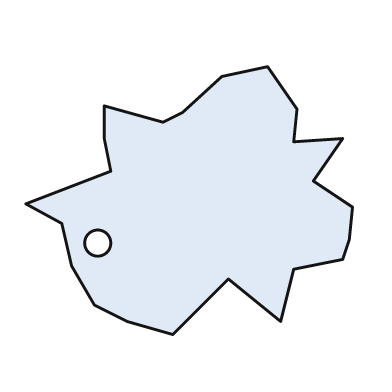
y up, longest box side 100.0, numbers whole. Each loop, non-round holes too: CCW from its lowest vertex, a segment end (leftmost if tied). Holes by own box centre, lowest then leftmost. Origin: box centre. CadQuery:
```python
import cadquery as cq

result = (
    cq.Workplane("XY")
    .moveTo(-5.0, -41.0)
    .lineTo(12.0, -24.0)
    .lineTo(28.0, -37.0)
    .lineTo(32.0, -21.0)
    .lineTo(47.0, -18.0)
    .lineTo(49.0, -12.0)
    .lineTo(50.0, -2.0)
    .lineTo(38.0, 6.0)
    .lineTo(47.0, 19.0)
    .lineTo(32.0, 18.0)
    .lineTo(33.0, 28.0)
    .lineTo(24.0, 41.0)
    .lineTo(10.0, 38.0)
    .lineTo(-2.0, 27.0)
    .lineTo(-8.0, 24.0)
    .lineTo(-26.0, 29.0)
    .lineTo(-26.0, 19.0)
    .lineTo(-24.0, 9.0)
    .lineTo(-50.0, -1.0)
    .lineTo(-39.0, -7.0)
    .lineTo(-36.0, -20.0)
    .lineTo(-29.0, -32.0)
    .lineTo(-19.0, -37.0)
    .close()
    .moveTo(-28.0, -13.0)
    .circle(4.0)
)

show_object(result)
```